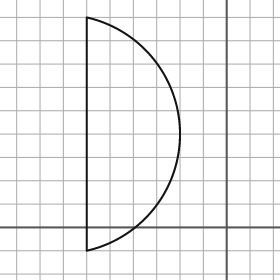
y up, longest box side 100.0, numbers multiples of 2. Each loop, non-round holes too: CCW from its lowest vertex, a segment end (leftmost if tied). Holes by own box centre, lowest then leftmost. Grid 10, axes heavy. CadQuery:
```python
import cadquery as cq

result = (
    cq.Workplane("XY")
    .moveTo(-60.0, -10.0)
    .threePointArc((-20.0, 40.0), (-60.0, 90.0))
    .close()
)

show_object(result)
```